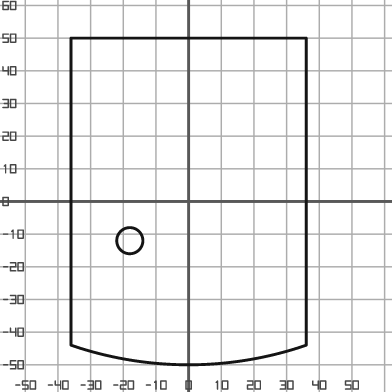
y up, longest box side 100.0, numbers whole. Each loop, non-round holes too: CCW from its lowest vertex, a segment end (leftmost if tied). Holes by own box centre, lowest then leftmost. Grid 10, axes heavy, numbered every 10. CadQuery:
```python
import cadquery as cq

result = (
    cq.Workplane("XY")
    .moveTo(-36.0, -44.0)
    .threePointArc((0.0, -50.0), (36.0, -44.0))
    .lineTo(36.0, 50.0)
    .lineTo(-36.0, 50.0)
    .close()
    .moveTo(-18.0, -12.0)
    .circle(4.0)
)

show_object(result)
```